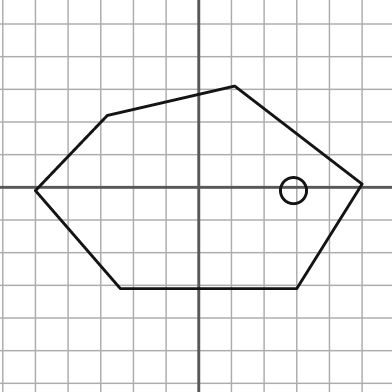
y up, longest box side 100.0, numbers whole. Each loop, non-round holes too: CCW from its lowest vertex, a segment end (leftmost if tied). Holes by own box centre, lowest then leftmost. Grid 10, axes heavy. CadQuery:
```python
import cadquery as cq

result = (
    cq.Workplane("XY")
    .moveTo(-24.0, -31.0)
    .lineTo(30.0, -31.0)
    .lineTo(50.0, 1.0)
    .lineTo(11.0, 31.0)
    .lineTo(-28.0, 22.0)
    .lineTo(-50.0, -1.0)
    .close()
    .moveTo(29.0, -1.0)
    .circle(4.0)
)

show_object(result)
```